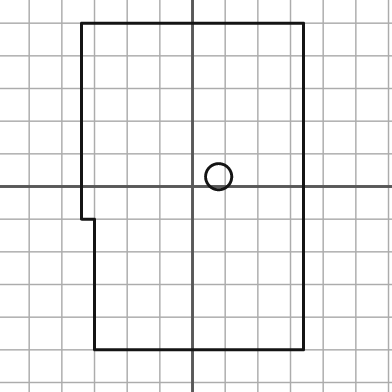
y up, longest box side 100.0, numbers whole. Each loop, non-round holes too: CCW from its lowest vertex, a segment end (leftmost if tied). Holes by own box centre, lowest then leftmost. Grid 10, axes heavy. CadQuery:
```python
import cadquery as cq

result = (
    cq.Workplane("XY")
    .moveTo(-30.0, -50.0)
    .lineTo(34.0, -50.0)
    .lineTo(34.0, 50.0)
    .lineTo(-34.0, 50.0)
    .lineTo(-34.0, -10.0)
    .lineTo(-30.0, -10.0)
    .close()
    .moveTo(8.0, 3.0)
    .circle(4.0)
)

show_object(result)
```